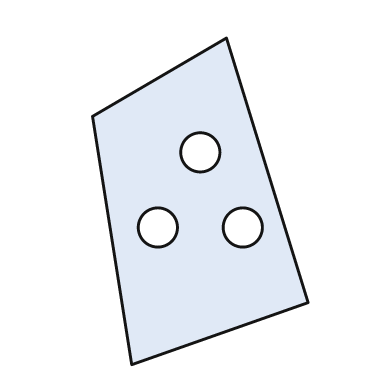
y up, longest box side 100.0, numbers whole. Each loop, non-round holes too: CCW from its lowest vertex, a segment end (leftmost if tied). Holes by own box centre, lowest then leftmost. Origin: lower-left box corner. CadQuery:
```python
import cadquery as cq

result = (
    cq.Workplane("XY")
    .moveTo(12.0, 0.0)
    .lineTo(66.0, 19.0)
    .lineTo(41.0, 100.0)
    .lineTo(0.0, 76.0)
    .close()
    .moveTo(20.0, 42.0)
    .circle(6.0)
    .moveTo(46.0, 42.0)
    .circle(6.0)
    .moveTo(33.0, 65.0)
    .circle(6.0)
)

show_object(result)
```